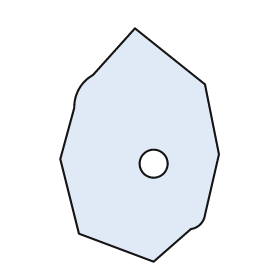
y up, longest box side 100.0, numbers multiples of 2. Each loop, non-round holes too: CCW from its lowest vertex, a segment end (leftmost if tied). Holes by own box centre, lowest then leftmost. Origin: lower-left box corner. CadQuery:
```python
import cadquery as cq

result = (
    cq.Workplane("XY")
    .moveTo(40.0, 0.0)
    .lineTo(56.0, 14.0)
    .threePointArc((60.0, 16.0), (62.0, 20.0))
    .lineTo(68.0, 46.0)
    .lineTo(62.0, 76.0)
    .lineTo(32.0, 100.0)
    .lineTo(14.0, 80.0)
    .threePointArc((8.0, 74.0), (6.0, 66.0))
    .lineTo(0.0, 44.0)
    .lineTo(8.0, 12.0)
    .close()
    .moveTo(40.0, 42.0)
    .circle(6.0)
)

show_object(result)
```